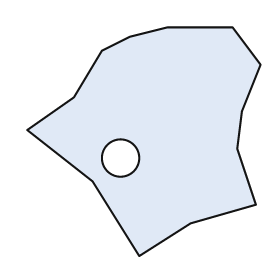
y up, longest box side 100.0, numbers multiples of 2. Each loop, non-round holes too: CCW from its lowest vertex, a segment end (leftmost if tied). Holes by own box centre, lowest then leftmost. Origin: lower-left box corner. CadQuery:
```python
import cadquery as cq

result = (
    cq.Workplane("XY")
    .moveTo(48.0, 0.0)
    .lineTo(70.0, 14.0)
    .lineTo(98.0, 22.0)
    .lineTo(90.0, 46.0)
    .lineTo(92.0, 62.0)
    .lineTo(100.0, 82.0)
    .lineTo(88.0, 98.0)
    .lineTo(60.0, 98.0)
    .lineTo(44.0, 94.0)
    .lineTo(32.0, 88.0)
    .lineTo(20.0, 68.0)
    .lineTo(0.0, 54.0)
    .lineTo(28.0, 32.0)
    .close()
    .moveTo(40.0, 42.0)
    .circle(8.0)
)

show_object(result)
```